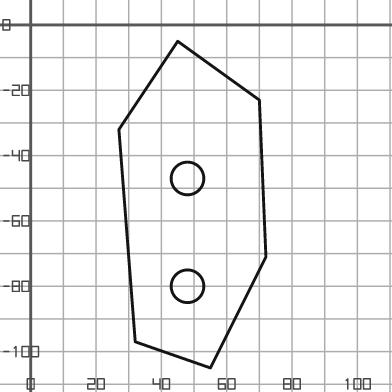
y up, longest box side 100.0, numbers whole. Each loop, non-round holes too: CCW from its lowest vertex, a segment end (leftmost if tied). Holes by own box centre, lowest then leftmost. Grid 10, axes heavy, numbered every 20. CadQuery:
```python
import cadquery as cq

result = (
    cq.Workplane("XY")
    .moveTo(55.0, -105.0)
    .lineTo(72.0, -71.0)
    .lineTo(70.0, -23.0)
    .lineTo(45.0, -5.0)
    .lineTo(27.0, -32.0)
    .lineTo(32.0, -97.0)
    .close()
    .moveTo(48.0, -80.0)
    .circle(5.0)
    .moveTo(48.0, -47.0)
    .circle(5.0)
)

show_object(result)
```